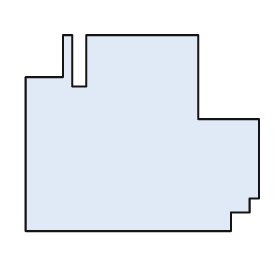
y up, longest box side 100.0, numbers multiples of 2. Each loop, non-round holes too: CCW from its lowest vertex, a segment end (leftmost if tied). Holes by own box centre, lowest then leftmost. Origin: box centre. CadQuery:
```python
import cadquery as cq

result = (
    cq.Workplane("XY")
    .moveTo(-50.0, -42.0)
    .lineTo(38.0, -42.0)
    .lineTo(38.0, -34.0)
    .lineTo(46.0, -34.0)
    .lineTo(46.0, -28.0)
    .lineTo(50.0, -28.0)
    .lineTo(50.0, 6.0)
    .lineTo(24.0, 6.0)
    .lineTo(24.0, 42.0)
    .lineTo(-24.0, 42.0)
    .lineTo(-24.0, 20.0)
    .lineTo(-30.0, 20.0)
    .lineTo(-30.0, 42.0)
    .lineTo(-34.0, 42.0)
    .lineTo(-34.0, 24.0)
    .lineTo(-50.0, 24.0)
    .close()
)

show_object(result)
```